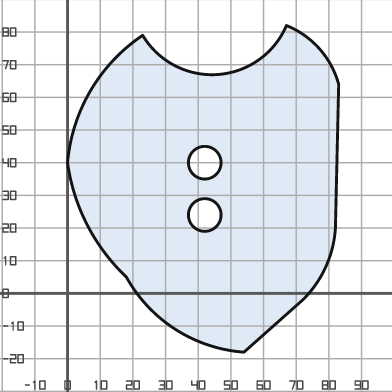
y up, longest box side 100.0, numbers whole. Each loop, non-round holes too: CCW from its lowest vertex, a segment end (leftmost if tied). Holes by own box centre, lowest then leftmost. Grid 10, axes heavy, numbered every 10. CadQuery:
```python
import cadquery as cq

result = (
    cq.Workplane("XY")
    .moveTo(54.0, -18.0)
    .lineTo(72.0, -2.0)
    .threePointArc((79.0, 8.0), (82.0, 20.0))
    .lineTo(83.0, 64.0)
    .threePointArc((77.0, 75.0), (67.0, 82.0))
    .threePointArc((46.0, 67.0), (23.0, 79.0))
    .threePointArc((7.0, 62.0), (0.0, 40.0))
    .threePointArc((6.0, 21.0), (18.0, 5.0))
    .threePointArc((33.0, -11.0), (54.0, -18.0))
    .close()
    .moveTo(42.0, 24.0)
    .circle(5.0)
    .moveTo(42.0, 40.0)
    .circle(5.0)
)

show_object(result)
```